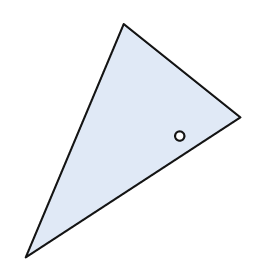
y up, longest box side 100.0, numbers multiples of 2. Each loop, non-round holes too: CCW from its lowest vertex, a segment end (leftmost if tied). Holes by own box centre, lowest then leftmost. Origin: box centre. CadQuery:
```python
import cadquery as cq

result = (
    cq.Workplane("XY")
    .moveTo(-46.0, -50.0)
    .lineTo(46.0, 10.0)
    .lineTo(-4.0, 50.0)
    .close()
    .moveTo(20.0, 2.0)
    .circle(2.0)
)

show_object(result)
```